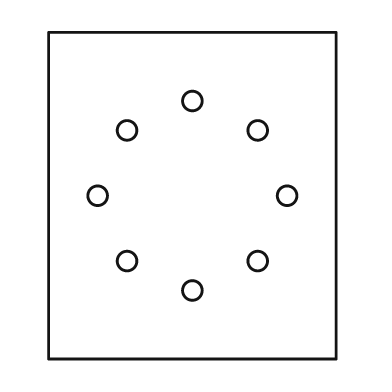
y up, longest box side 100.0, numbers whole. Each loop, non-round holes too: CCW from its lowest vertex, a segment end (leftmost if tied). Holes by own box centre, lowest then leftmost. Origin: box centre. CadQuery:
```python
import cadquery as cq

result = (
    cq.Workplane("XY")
    .moveTo(-44.0, -50.0)
    .lineTo(44.0, -50.0)
    .lineTo(44.0, 50.0)
    .lineTo(-44.0, 50.0)
    .close()
    .moveTo(0.0, -29.0)
    .circle(3.0)
    .moveTo(-20.0, -20.0)
    .circle(3.0)
    .moveTo(20.0, -20.0)
    .circle(3.0)
    .moveTo(-29.0, 0.0)
    .circle(3.0)
    .moveTo(29.0, 0.0)
    .circle(3.0)
    .moveTo(-20.0, 20.0)
    .circle(3.0)
    .moveTo(20.0, 20.0)
    .circle(3.0)
    .moveTo(0.0, 29.0)
    .circle(3.0)
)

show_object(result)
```